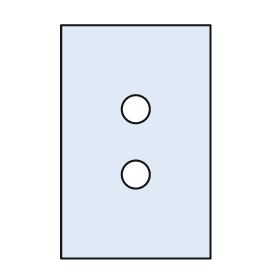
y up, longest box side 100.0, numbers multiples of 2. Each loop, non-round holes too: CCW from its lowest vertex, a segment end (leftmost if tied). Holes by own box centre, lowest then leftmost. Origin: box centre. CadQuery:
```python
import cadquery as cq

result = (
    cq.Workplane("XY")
    .moveTo(-32.0, -50.0)
    .lineTo(32.0, -50.0)
    .lineTo(32.0, 50.0)
    .lineTo(-32.0, 50.0)
    .close()
    .moveTo(0.0, -14.0)
    .circle(6.0)
    .moveTo(0.0, 14.0)
    .circle(6.0)
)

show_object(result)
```